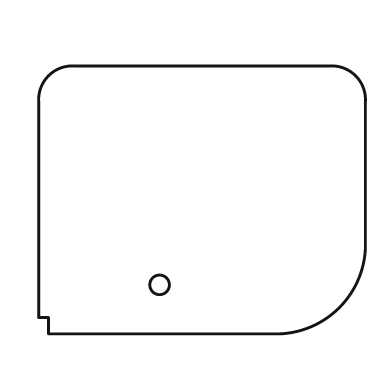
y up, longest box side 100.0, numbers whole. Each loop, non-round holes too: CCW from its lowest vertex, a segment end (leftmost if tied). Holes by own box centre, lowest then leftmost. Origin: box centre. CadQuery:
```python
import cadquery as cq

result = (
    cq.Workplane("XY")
    .moveTo(-47.0, -41.0)
    .lineTo(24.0, -41.0)
    .threePointArc((42.0, -33.0), (50.0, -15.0))
    .lineTo(50.0, 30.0)
    .threePointArc((47.0, 38.0), (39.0, 41.0))
    .lineTo(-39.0, 41.0)
    .threePointArc((-47.0, 38.0), (-50.0, 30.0))
    .lineTo(-50.0, -36.0)
    .lineTo(-47.0, -36.0)
    .close()
    .moveTo(-13.0, -26.0)
    .circle(3.0)
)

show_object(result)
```